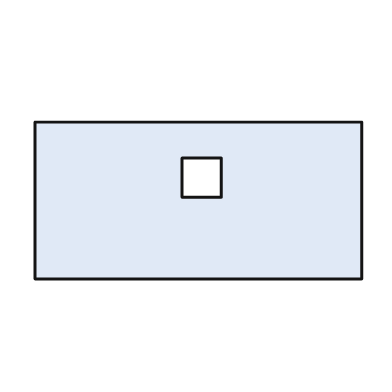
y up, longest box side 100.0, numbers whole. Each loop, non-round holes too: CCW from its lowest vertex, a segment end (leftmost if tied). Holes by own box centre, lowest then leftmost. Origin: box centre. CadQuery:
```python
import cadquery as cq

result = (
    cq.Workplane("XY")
    .moveTo(-50.0, -24.0)
    .lineTo(50.0, -24.0)
    .lineTo(50.0, 24.0)
    .lineTo(-50.0, 24.0)
    .close()
    .moveTo(-5.0, 1.0)
    .lineTo(7.0, 1.0)
    .lineTo(7.0, 13.0)
    .lineTo(-5.0, 13.0)
    .close()
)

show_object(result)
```